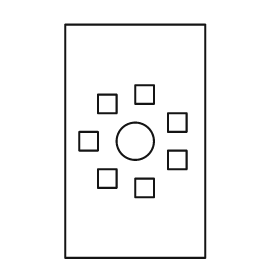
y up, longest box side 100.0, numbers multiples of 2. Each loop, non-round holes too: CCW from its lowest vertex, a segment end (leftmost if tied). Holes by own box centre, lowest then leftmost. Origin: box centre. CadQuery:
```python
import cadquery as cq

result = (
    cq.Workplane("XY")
    .moveTo(-30.0, -50.0)
    .lineTo(30.0, -50.0)
    .lineTo(30.0, 50.0)
    .lineTo(-30.0, 50.0)
    .close()
    .moveTo(0.0, -24.0)
    .lineTo(8.0, -24.0)
    .lineTo(8.0, -16.0)
    .lineTo(0.0, -16.0)
    .close()
    .moveTo(-16.0, -20.0)
    .lineTo(-8.0, -20.0)
    .lineTo(-8.0, -12.0)
    .lineTo(-16.0, -12.0)
    .close()
    .moveTo(14.0, -12.0)
    .lineTo(22.0, -12.0)
    .lineTo(22.0, -4.0)
    .lineTo(14.0, -4.0)
    .close()
    .moveTo(-24.0, -4.0)
    .lineTo(-16.0, -4.0)
    .lineTo(-16.0, 4.0)
    .lineTo(-24.0, 4.0)
    .close()
    .moveTo(0.0, 0.0)
    .circle(8.0)
    .moveTo(14.0, 4.0)
    .lineTo(22.0, 4.0)
    .lineTo(22.0, 12.0)
    .lineTo(14.0, 12.0)
    .close()
    .moveTo(-16.0, 12.0)
    .lineTo(-8.0, 12.0)
    .lineTo(-8.0, 20.0)
    .lineTo(-16.0, 20.0)
    .close()
    .moveTo(0.0, 16.0)
    .lineTo(8.0, 16.0)
    .lineTo(8.0, 24.0)
    .lineTo(0.0, 24.0)
    .close()
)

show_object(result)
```